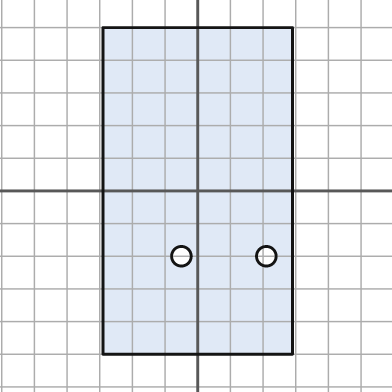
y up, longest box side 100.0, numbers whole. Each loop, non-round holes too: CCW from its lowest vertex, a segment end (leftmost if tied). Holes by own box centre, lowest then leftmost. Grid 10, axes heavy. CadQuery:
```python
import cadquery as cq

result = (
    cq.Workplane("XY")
    .moveTo(-29.0, -50.0)
    .lineTo(29.0, -50.0)
    .lineTo(29.0, 50.0)
    .lineTo(-29.0, 50.0)
    .close()
    .moveTo(-5.0, -20.0)
    .circle(3.0)
    .moveTo(21.0, -20.0)
    .circle(3.0)
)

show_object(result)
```